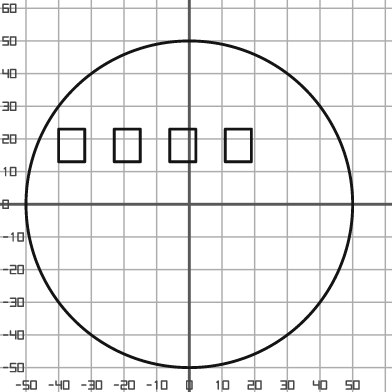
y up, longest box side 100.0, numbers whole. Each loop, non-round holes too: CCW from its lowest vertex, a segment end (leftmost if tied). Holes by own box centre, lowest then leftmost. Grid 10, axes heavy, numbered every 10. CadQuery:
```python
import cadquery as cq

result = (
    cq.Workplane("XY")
    .moveTo(0.0, 0.0)
    .circle(50.0)
    .moveTo(-40.0, 13.0)
    .lineTo(-32.0, 13.0)
    .lineTo(-32.0, 23.0)
    .lineTo(-40.0, 23.0)
    .close()
    .moveTo(-23.0, 13.0)
    .lineTo(-15.0, 13.0)
    .lineTo(-15.0, 23.0)
    .lineTo(-23.0, 23.0)
    .close()
    .moveTo(-6.0, 13.0)
    .lineTo(2.0, 13.0)
    .lineTo(2.0, 23.0)
    .lineTo(-6.0, 23.0)
    .close()
    .moveTo(11.0, 13.0)
    .lineTo(19.0, 13.0)
    .lineTo(19.0, 23.0)
    .lineTo(11.0, 23.0)
    .close()
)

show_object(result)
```